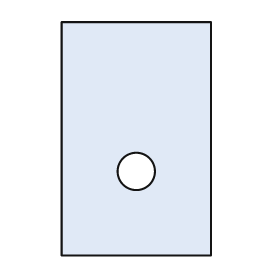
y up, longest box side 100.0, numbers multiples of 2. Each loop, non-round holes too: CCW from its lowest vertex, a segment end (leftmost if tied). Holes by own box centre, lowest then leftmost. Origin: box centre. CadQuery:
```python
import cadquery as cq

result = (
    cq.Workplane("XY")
    .moveTo(-32.0, -50.0)
    .lineTo(32.0, -50.0)
    .lineTo(32.0, 50.0)
    .lineTo(-32.0, 50.0)
    .close()
    .moveTo(0.0, -14.0)
    .circle(8.0)
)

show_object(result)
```